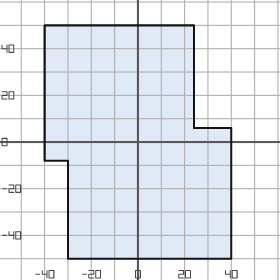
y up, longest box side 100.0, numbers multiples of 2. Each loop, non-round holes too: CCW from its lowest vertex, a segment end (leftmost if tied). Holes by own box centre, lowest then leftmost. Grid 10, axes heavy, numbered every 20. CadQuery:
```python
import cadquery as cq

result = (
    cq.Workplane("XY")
    .moveTo(-30.0, -50.0)
    .lineTo(40.0, -50.0)
    .lineTo(40.0, 6.0)
    .lineTo(24.0, 6.0)
    .lineTo(24.0, 50.0)
    .lineTo(-40.0, 50.0)
    .lineTo(-40.0, -8.0)
    .lineTo(-30.0, -8.0)
    .close()
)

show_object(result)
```